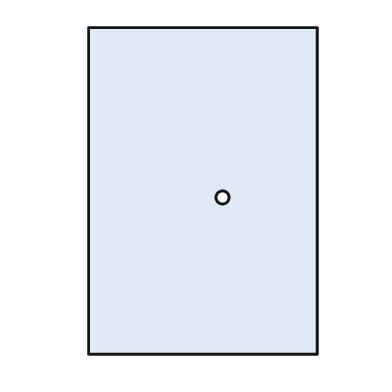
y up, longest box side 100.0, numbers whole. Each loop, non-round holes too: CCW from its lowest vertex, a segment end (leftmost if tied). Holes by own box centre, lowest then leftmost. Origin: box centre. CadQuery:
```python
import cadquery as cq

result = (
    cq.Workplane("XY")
    .moveTo(-35.0, -50.0)
    .lineTo(35.0, -50.0)
    .lineTo(35.0, 50.0)
    .lineTo(-35.0, 50.0)
    .close()
    .moveTo(6.0, -2.0)
    .circle(2.0)
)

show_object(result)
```